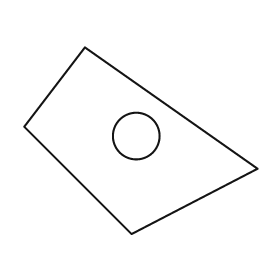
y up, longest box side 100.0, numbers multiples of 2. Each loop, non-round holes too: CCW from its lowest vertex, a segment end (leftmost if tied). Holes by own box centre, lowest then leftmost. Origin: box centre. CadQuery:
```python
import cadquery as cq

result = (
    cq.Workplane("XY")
    .moveTo(-4.0, -40.0)
    .lineTo(50.0, -12.0)
    .lineTo(-24.0, 40.0)
    .lineTo(-50.0, 6.0)
    .close()
    .moveTo(-2.0, 2.0)
    .circle(10.0)
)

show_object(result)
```